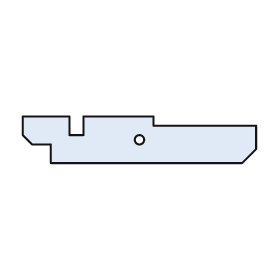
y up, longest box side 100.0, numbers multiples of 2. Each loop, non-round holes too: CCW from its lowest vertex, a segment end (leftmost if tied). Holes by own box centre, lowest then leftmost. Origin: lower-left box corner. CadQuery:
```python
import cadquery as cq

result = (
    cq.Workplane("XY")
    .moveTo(12.0, 0.0)
    .lineTo(94.0, 0.0)
    .lineTo(100.0, 6.0)
    .lineTo(100.0, 16.0)
    .lineTo(56.0, 16.0)
    .lineTo(56.0, 20.0)
    .lineTo(26.0, 20.0)
    .lineTo(26.0, 12.0)
    .lineTo(20.0, 12.0)
    .lineTo(20.0, 20.0)
    .lineTo(0.0, 20.0)
    .lineTo(0.0, 12.0)
    .lineTo(4.0, 8.0)
    .lineTo(12.0, 8.0)
    .close()
    .moveTo(50.0, 10.0)
    .circle(2.0)
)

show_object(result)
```